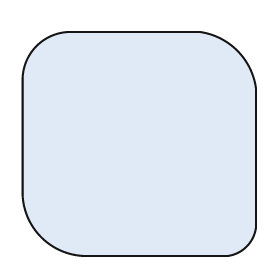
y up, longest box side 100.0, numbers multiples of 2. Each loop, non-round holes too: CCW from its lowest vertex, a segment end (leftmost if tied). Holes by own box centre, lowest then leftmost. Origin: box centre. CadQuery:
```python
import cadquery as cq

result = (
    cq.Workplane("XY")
    .moveTo(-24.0, -48.0)
    .lineTo(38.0, -48.0)
    .threePointArc((46.0, -44.0), (50.0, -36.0))
    .lineTo(50.0, 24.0)
    .threePointArc((42.0, 40.0), (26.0, 48.0))
    .lineTo(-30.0, 48.0)
    .threePointArc((-44.0, 42.0), (-50.0, 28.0))
    .lineTo(-50.0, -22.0)
    .threePointArc((-42.0, -40.0), (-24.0, -48.0))
    .close()
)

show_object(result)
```